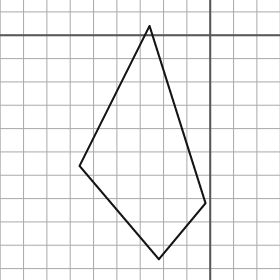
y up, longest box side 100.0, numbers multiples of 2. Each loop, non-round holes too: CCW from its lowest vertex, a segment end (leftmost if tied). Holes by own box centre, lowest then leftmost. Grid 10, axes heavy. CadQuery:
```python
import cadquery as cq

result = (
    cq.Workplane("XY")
    .moveTo(-22.0, -96.0)
    .lineTo(-2.0, -72.0)
    .lineTo(-26.0, 4.0)
    .lineTo(-56.0, -56.0)
    .close()
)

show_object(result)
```